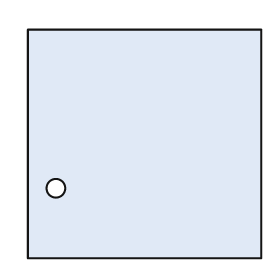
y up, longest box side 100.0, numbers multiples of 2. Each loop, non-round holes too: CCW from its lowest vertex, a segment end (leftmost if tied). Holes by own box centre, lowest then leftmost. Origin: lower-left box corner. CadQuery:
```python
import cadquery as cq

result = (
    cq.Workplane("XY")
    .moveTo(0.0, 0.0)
    .lineTo(100.0, 0.0)
    .lineTo(100.0, 98.0)
    .lineTo(0.0, 98.0)
    .close()
    .moveTo(12.0, 30.0)
    .circle(4.0)
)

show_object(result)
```